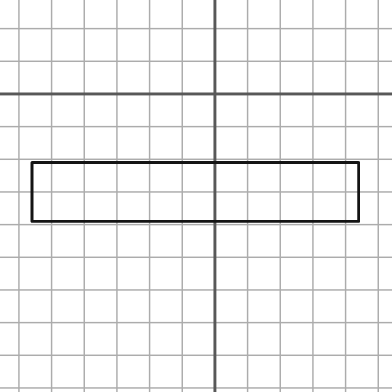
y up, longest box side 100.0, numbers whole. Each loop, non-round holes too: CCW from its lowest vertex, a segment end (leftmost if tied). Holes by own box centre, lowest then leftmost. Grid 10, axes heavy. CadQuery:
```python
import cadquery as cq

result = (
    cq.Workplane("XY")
    .moveTo(-56.0, -39.0)
    .lineTo(44.0, -39.0)
    .lineTo(44.0, -21.0)
    .lineTo(-56.0, -21.0)
    .close()
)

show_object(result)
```